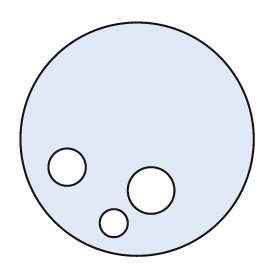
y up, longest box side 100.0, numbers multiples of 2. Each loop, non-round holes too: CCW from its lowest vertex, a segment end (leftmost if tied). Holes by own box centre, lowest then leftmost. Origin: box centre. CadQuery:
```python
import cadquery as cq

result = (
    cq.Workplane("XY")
    .moveTo(0.0, 0.0)
    .circle(50.0)
    .moveTo(-10.0, -36.0)
    .circle(6.0)
    .moveTo(6.0, -22.0)
    .circle(10.0)
    .moveTo(-30.0, -12.0)
    .circle(8.0)
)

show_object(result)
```